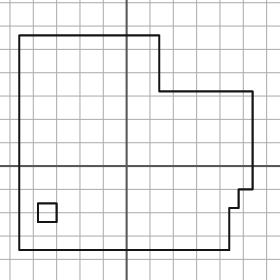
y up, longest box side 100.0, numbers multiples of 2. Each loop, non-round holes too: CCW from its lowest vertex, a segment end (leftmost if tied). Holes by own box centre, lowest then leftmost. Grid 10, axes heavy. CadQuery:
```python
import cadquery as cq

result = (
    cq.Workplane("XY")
    .moveTo(-46.0, -36.0)
    .lineTo(44.0, -36.0)
    .lineTo(44.0, -18.0)
    .lineTo(48.0, -18.0)
    .lineTo(48.0, -10.0)
    .lineTo(54.0, -10.0)
    .lineTo(54.0, 32.0)
    .lineTo(14.0, 32.0)
    .lineTo(14.0, 56.0)
    .lineTo(-46.0, 56.0)
    .close()
    .moveTo(-38.0, -24.0)
    .lineTo(-30.0, -24.0)
    .lineTo(-30.0, -16.0)
    .lineTo(-38.0, -16.0)
    .close()
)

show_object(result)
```